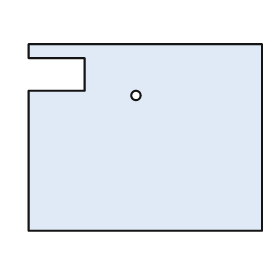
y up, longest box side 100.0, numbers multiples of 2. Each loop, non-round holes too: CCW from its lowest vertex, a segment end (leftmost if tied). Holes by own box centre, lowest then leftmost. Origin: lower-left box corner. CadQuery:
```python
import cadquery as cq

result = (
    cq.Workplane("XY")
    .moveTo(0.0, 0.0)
    .lineTo(100.0, 0.0)
    .lineTo(100.0, 80.0)
    .lineTo(0.0, 80.0)
    .lineTo(0.0, 74.0)
    .lineTo(24.0, 74.0)
    .lineTo(24.0, 60.0)
    .lineTo(0.0, 60.0)
    .close()
    .moveTo(46.0, 58.0)
    .circle(2.0)
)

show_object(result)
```